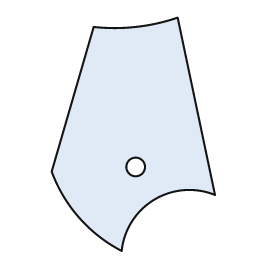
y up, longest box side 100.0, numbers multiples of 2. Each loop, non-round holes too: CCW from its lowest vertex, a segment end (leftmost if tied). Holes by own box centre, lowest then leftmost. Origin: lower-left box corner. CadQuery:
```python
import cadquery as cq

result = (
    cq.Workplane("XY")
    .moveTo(30.0, 0.0)
    .threePointArc((44.0, 22.0), (70.0, 24.0))
    .lineTo(54.0, 100.0)
    .threePointArc((36.0, 96.0), (18.0, 96.0))
    .lineTo(0.0, 34.0)
    .threePointArc((12.0, 14.0), (30.0, 0.0))
    .close()
    .moveTo(36.0, 36.0)
    .circle(4.0)
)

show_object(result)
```